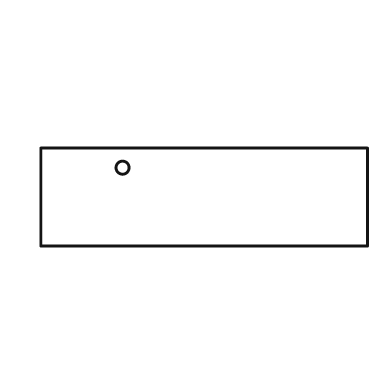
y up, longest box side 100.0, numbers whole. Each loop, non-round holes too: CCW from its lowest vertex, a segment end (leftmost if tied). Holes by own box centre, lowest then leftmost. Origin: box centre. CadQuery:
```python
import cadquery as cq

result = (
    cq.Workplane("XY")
    .moveTo(-50.0, -15.0)
    .lineTo(50.0, -15.0)
    .lineTo(50.0, 15.0)
    .lineTo(-50.0, 15.0)
    .close()
    .moveTo(-25.0, 9.0)
    .circle(2.0)
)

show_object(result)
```